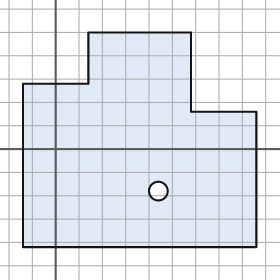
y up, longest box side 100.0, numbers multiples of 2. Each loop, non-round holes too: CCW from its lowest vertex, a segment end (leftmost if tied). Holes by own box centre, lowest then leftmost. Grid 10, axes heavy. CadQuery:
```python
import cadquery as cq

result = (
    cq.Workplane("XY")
    .moveTo(-14.0, -42.0)
    .lineTo(86.0, -42.0)
    .lineTo(86.0, 16.0)
    .lineTo(58.0, 16.0)
    .lineTo(58.0, 50.0)
    .lineTo(14.0, 50.0)
    .lineTo(14.0, 28.0)
    .lineTo(-14.0, 28.0)
    .close()
    .moveTo(44.0, -18.0)
    .circle(4.0)
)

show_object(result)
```